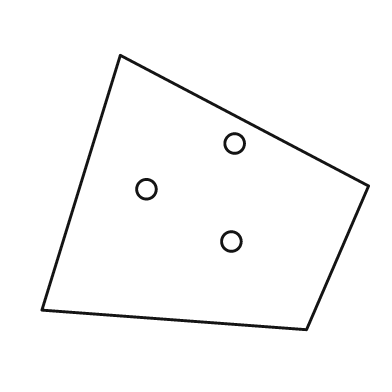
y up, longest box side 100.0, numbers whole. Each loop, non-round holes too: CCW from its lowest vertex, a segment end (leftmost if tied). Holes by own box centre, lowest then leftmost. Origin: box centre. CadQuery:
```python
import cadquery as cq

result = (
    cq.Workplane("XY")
    .moveTo(31.0, -42.0)
    .lineTo(50.0, 2.0)
    .lineTo(-26.0, 42.0)
    .lineTo(-50.0, -36.0)
    .close()
    .moveTo(8.0, -15.0)
    .circle(3.0)
    .moveTo(-18.0, 1.0)
    .circle(3.0)
    .moveTo(9.0, 15.0)
    .circle(3.0)
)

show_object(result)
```